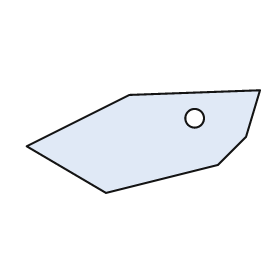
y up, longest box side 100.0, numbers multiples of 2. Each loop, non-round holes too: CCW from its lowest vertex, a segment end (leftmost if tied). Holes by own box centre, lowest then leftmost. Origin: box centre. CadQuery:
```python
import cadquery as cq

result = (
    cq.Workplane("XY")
    .moveTo(-16.0, -22.0)
    .lineTo(32.0, -10.0)
    .lineTo(44.0, 2.0)
    .lineTo(50.0, 22.0)
    .lineTo(-6.0, 20.0)
    .lineTo(-50.0, -2.0)
    .close()
    .moveTo(22.0, 10.0)
    .circle(4.0)
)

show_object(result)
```